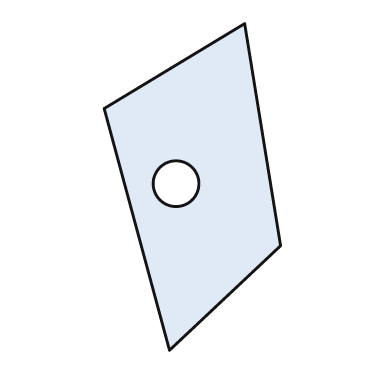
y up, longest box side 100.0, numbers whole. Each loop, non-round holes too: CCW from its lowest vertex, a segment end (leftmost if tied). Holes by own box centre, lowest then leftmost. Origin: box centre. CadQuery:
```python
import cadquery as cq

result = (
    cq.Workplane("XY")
    .moveTo(-7.0, -50.0)
    .lineTo(27.0, -18.0)
    .lineTo(16.0, 50.0)
    .lineTo(-27.0, 24.0)
    .close()
    .moveTo(-5.0, 1.0)
    .circle(7.0)
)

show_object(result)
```